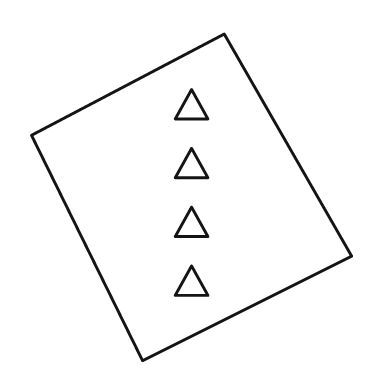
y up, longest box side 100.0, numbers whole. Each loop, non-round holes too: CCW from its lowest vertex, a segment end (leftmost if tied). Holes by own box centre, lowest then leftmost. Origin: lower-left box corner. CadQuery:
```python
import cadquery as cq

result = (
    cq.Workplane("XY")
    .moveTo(34.0, 0.0)
    .lineTo(98.0, 32.0)
    .lineTo(59.0, 100.0)
    .lineTo(0.0, 69.0)
    .close()
    .moveTo(44.0, 20.0)
    .lineTo(54.0, 20.0)
    .lineTo(49.0, 29.0)
    .close()
    .moveTo(44.0, 38.0)
    .lineTo(54.0, 38.0)
    .lineTo(49.0, 47.0)
    .close()
    .moveTo(44.0, 56.0)
    .lineTo(54.0, 56.0)
    .lineTo(49.0, 65.0)
    .close()
    .moveTo(44.0, 74.0)
    .lineTo(54.0, 74.0)
    .lineTo(49.0, 83.0)
    .close()
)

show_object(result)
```